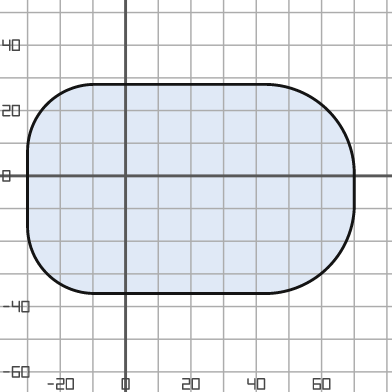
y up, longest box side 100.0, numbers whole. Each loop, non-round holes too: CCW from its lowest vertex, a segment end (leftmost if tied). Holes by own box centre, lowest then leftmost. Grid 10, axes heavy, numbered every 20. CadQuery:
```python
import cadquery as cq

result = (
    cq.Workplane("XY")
    .moveTo(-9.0, -36.0)
    .lineTo(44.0, -36.0)
    .threePointArc((62.0, -28.0), (70.0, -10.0))
    .lineTo(70.0, 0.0)
    .threePointArc((62.0, 20.0), (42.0, 28.0))
    .lineTo(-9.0, 28.0)
    .threePointArc((-24.0, 22.0), (-30.0, 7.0))
    .lineTo(-30.0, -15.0)
    .threePointArc((-24.0, -30.0), (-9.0, -36.0))
    .close()
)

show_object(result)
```